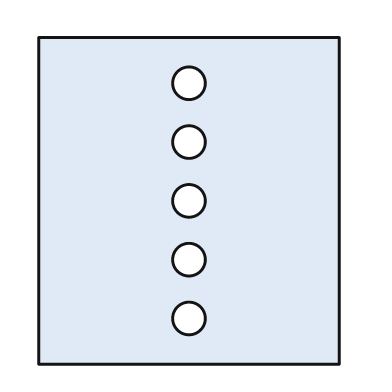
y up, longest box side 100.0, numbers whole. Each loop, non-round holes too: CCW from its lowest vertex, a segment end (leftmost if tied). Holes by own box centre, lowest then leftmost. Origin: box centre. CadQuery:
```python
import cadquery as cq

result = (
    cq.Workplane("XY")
    .moveTo(-46.0, -50.0)
    .lineTo(46.0, -50.0)
    .lineTo(46.0, 50.0)
    .lineTo(-46.0, 50.0)
    .close()
    .moveTo(0.0, -36.0)
    .circle(5.0)
    .moveTo(0.0, -18.0)
    .circle(5.0)
    .moveTo(0.0, 0.0)
    .circle(5.0)
    .moveTo(0.0, 18.0)
    .circle(5.0)
    .moveTo(0.0, 36.0)
    .circle(5.0)
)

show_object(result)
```